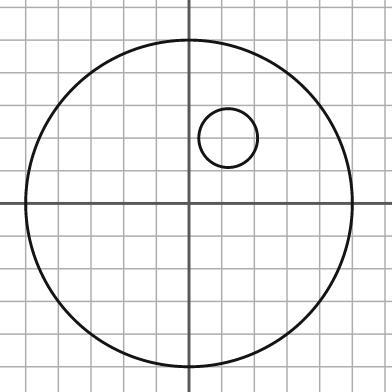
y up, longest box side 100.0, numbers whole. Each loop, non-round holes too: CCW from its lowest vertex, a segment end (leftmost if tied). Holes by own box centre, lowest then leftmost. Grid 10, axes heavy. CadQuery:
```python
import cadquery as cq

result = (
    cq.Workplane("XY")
    .moveTo(0.0, 0.0)
    .circle(50.0)
    .moveTo(12.0, 20.0)
    .circle(9.0)
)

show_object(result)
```